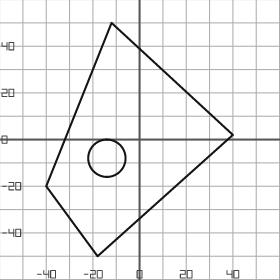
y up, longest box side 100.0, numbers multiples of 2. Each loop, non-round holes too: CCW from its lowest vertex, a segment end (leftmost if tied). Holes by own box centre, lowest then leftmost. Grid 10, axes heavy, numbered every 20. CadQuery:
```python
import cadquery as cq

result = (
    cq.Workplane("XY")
    .moveTo(-18.0, -50.0)
    .lineTo(40.0, 2.0)
    .lineTo(-12.0, 50.0)
    .lineTo(-40.0, -20.0)
    .close()
    .moveTo(-14.0, -8.0)
    .circle(8.0)
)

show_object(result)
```